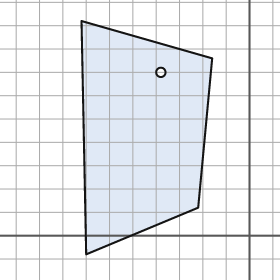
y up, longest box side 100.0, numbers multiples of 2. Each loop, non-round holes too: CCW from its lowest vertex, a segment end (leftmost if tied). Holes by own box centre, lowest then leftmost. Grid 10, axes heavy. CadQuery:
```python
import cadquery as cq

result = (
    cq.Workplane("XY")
    .moveTo(-70.0, -8.0)
    .lineTo(-22.0, 12.0)
    .lineTo(-16.0, 76.0)
    .lineTo(-72.0, 92.0)
    .close()
    .moveTo(-38.0, 70.0)
    .circle(2.0)
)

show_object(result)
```